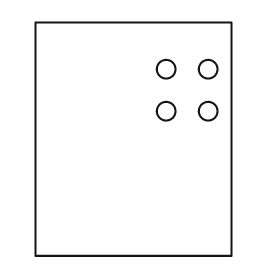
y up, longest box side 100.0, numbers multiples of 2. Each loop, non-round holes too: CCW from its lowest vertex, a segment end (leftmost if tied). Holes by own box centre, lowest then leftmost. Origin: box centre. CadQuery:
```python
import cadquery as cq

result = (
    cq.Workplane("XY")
    .moveTo(-42.0, -50.0)
    .lineTo(42.0, -50.0)
    .lineTo(42.0, 50.0)
    .lineTo(-42.0, 50.0)
    .close()
    .moveTo(14.0, 12.0)
    .circle(4.0)
    .moveTo(32.0, 12.0)
    .circle(4.0)
    .moveTo(14.0, 30.0)
    .circle(4.0)
    .moveTo(32.0, 30.0)
    .circle(4.0)
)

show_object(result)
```